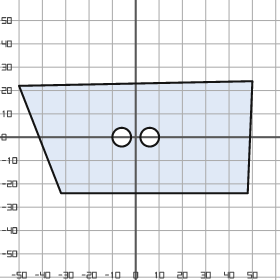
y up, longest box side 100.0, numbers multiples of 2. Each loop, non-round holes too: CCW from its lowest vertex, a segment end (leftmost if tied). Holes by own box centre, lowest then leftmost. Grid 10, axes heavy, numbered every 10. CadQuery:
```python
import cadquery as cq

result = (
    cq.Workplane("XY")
    .moveTo(-32.0, -24.0)
    .lineTo(48.0, -24.0)
    .lineTo(50.0, 24.0)
    .lineTo(-50.0, 22.0)
    .close()
    .moveTo(-6.0, 0.0)
    .circle(4.0)
    .moveTo(6.0, 0.0)
    .circle(4.0)
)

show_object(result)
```